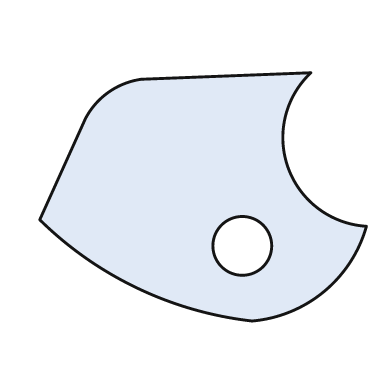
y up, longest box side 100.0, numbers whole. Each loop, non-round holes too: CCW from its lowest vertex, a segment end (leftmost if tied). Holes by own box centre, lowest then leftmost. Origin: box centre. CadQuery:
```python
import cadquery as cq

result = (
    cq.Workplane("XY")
    .moveTo(15.0, -38.0)
    .threePointArc((37.0, -29.0), (50.0, -9.0))
    .threePointArc((26.0, 9.0), (33.0, 38.0))
    .lineTo(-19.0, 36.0)
    .threePointArc((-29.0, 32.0), (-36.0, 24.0))
    .lineTo(-50.0, -7.0)
    .threePointArc((-20.0, -28.0), (15.0, -38.0))
    .close()
    .moveTo(12.0, -15.0)
    .circle(9.0)
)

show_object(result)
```